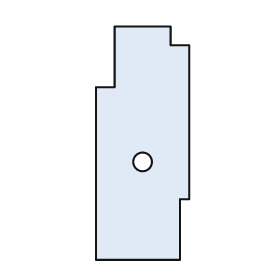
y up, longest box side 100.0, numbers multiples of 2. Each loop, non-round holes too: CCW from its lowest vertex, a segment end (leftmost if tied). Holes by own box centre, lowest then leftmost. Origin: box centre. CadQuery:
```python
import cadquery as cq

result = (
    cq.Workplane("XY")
    .moveTo(-20.0, -50.0)
    .lineTo(16.0, -50.0)
    .lineTo(16.0, -24.0)
    .lineTo(20.0, -24.0)
    .lineTo(20.0, 42.0)
    .lineTo(12.0, 42.0)
    .lineTo(12.0, 50.0)
    .lineTo(-12.0, 50.0)
    .lineTo(-12.0, 24.0)
    .lineTo(-20.0, 24.0)
    .close()
    .moveTo(0.0, -8.0)
    .circle(4.0)
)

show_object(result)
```